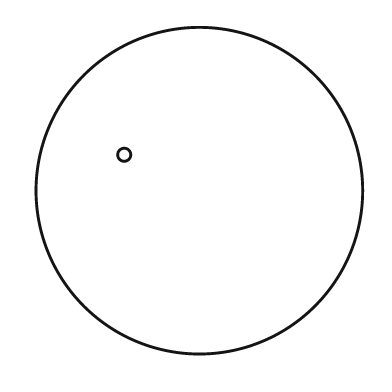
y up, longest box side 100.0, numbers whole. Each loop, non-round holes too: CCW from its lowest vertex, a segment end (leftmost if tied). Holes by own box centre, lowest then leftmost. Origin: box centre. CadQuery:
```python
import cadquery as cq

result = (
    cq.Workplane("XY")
    .moveTo(0.0, 0.0)
    .circle(50.0)
    .moveTo(-23.0, 11.0)
    .circle(2.0)
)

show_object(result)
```